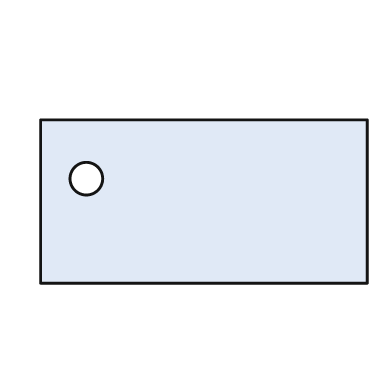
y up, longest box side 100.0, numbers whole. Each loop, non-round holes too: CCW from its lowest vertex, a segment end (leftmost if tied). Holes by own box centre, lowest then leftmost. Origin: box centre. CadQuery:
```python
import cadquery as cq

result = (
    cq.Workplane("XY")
    .moveTo(-50.0, -25.0)
    .lineTo(50.0, -25.0)
    .lineTo(50.0, 25.0)
    .lineTo(-50.0, 25.0)
    .close()
    .moveTo(-36.0, 7.0)
    .circle(5.0)
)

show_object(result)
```